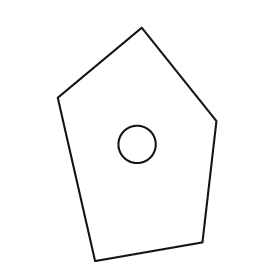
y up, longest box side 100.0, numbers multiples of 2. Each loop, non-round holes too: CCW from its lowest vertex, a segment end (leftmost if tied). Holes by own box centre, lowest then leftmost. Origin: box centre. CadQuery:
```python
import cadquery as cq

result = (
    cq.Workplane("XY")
    .moveTo(-18.0, -50.0)
    .lineTo(28.0, -42.0)
    .lineTo(34.0, 10.0)
    .lineTo(2.0, 50.0)
    .lineTo(-34.0, 20.0)
    .close()
    .moveTo(0.0, 0.0)
    .circle(8.0)
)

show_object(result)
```